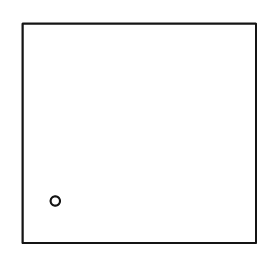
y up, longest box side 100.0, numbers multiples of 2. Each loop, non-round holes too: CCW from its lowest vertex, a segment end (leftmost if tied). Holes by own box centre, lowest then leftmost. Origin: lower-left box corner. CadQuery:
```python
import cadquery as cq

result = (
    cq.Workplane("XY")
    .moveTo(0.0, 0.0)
    .lineTo(100.0, 0.0)
    .lineTo(100.0, 94.0)
    .lineTo(0.0, 94.0)
    .close()
    .moveTo(14.0, 18.0)
    .circle(2.0)
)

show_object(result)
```